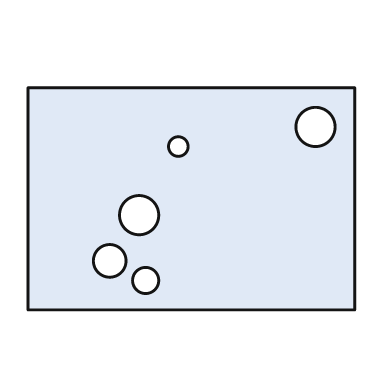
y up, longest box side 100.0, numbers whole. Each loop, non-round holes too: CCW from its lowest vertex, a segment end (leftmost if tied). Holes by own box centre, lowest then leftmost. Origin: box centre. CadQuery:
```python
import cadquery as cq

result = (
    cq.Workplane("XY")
    .moveTo(-50.0, -34.0)
    .lineTo(50.0, -34.0)
    .lineTo(50.0, 34.0)
    .lineTo(-50.0, 34.0)
    .close()
    .moveTo(-14.0, -25.0)
    .circle(4.0)
    .moveTo(-25.0, -19.0)
    .circle(5.0)
    .moveTo(-16.0, -5.0)
    .circle(6.0)
    .moveTo(-4.0, 16.0)
    .circle(3.0)
    .moveTo(38.0, 22.0)
    .circle(6.0)
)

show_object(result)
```